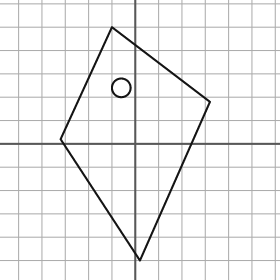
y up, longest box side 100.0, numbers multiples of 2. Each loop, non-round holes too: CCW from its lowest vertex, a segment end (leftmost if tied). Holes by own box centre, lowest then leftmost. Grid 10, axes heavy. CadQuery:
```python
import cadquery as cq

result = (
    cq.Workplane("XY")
    .moveTo(2.0, -50.0)
    .lineTo(32.0, 18.0)
    .lineTo(-10.0, 50.0)
    .lineTo(-32.0, 2.0)
    .close()
    .moveTo(-6.0, 24.0)
    .circle(4.0)
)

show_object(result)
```